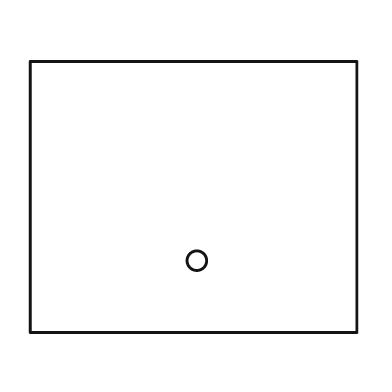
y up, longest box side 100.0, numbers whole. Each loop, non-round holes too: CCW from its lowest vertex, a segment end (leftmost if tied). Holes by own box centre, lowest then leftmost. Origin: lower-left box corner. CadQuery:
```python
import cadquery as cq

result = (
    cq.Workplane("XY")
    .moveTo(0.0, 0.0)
    .lineTo(100.0, 0.0)
    .lineTo(100.0, 83.0)
    .lineTo(0.0, 83.0)
    .close()
    .moveTo(51.0, 22.0)
    .circle(3.0)
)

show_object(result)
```